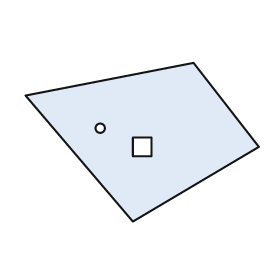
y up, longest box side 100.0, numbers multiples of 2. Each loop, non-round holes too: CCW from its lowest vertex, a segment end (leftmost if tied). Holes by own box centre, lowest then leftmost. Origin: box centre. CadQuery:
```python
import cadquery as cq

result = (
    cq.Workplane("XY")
    .moveTo(-4.0, -34.0)
    .lineTo(50.0, -2.0)
    .lineTo(22.0, 34.0)
    .lineTo(-50.0, 20.0)
    .close()
    .moveTo(-4.0, -6.0)
    .lineTo(4.0, -6.0)
    .lineTo(4.0, 2.0)
    .lineTo(-4.0, 2.0)
    .close()
    .moveTo(-18.0, 6.0)
    .circle(2.0)
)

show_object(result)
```